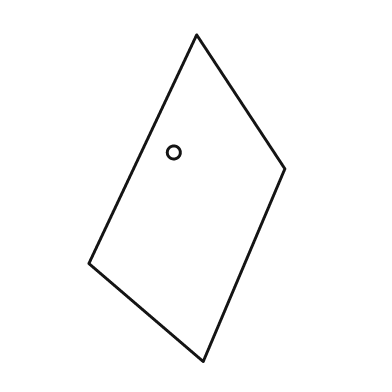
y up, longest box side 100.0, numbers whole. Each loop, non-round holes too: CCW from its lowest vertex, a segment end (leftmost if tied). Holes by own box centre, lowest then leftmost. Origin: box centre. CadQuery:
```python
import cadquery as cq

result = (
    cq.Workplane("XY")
    .moveTo(5.0, -50.0)
    .lineTo(30.0, 9.0)
    .lineTo(3.0, 50.0)
    .lineTo(-30.0, -20.0)
    .close()
    .moveTo(-4.0, 14.0)
    .circle(2.0)
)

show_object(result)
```